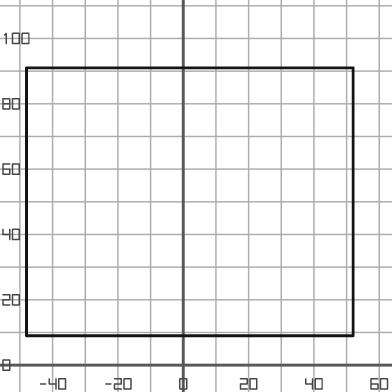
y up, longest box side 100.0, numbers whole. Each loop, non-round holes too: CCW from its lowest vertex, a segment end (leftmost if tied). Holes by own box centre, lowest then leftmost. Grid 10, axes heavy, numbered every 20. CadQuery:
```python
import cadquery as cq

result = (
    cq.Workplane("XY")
    .moveTo(-48.0, 9.0)
    .lineTo(52.0, 9.0)
    .lineTo(52.0, 91.0)
    .lineTo(-48.0, 91.0)
    .close()
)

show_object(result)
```